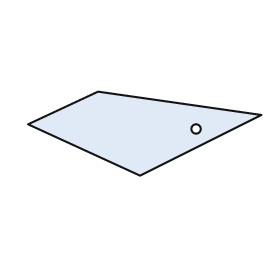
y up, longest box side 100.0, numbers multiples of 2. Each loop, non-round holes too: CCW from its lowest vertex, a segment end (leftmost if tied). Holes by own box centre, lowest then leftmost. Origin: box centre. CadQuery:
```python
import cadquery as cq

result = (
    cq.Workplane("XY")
    .moveTo(-2.0, -18.0)
    .lineTo(50.0, 8.0)
    .lineTo(-20.0, 18.0)
    .lineTo(-50.0, 4.0)
    .close()
    .moveTo(22.0, 2.0)
    .circle(2.0)
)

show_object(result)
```